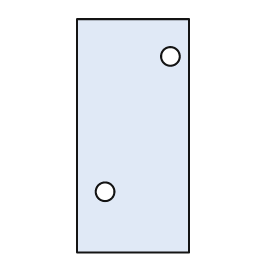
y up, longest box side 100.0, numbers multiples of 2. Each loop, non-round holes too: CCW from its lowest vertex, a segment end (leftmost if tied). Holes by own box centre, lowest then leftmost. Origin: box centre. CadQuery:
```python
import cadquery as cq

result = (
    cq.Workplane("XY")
    .moveTo(-24.0, -50.0)
    .lineTo(24.0, -50.0)
    .lineTo(24.0, 50.0)
    .lineTo(-24.0, 50.0)
    .close()
    .moveTo(-12.0, -24.0)
    .circle(4.0)
    .moveTo(16.0, 34.0)
    .circle(4.0)
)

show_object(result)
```